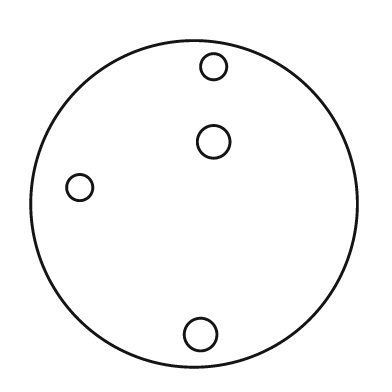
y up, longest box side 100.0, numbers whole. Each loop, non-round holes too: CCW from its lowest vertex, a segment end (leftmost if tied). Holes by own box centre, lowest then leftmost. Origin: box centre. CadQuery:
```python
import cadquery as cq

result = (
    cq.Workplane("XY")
    .moveTo(0.0, 0.0)
    .circle(50.0)
    .moveTo(2.0, -40.0)
    .circle(5.0)
    .moveTo(-35.0, 5.0)
    .circle(4.0)
    .moveTo(6.0, 19.0)
    .circle(5.0)
    .moveTo(6.0, 42.0)
    .circle(4.0)
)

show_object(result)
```